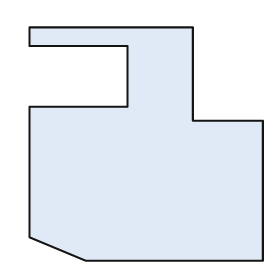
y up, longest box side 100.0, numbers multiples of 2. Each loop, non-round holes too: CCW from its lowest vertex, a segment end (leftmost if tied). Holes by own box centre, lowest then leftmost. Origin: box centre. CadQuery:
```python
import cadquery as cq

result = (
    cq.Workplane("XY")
    .moveTo(-26.0, -50.0)
    .lineTo(50.0, -50.0)
    .lineTo(50.0, 10.0)
    .lineTo(20.0, 10.0)
    .lineTo(20.0, 50.0)
    .lineTo(-50.0, 50.0)
    .lineTo(-50.0, 42.0)
    .lineTo(-8.0, 42.0)
    .lineTo(-8.0, 16.0)
    .lineTo(-50.0, 16.0)
    .lineTo(-50.0, -40.0)
    .close()
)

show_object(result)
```